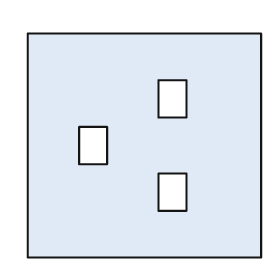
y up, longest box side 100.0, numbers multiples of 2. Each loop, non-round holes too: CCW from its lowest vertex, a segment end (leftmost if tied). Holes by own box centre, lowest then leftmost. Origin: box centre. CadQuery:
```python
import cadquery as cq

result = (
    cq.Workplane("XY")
    .moveTo(-50.0, -48.0)
    .lineTo(50.0, -48.0)
    .lineTo(50.0, 48.0)
    .lineTo(-50.0, 48.0)
    .close()
    .moveTo(6.0, -28.0)
    .lineTo(18.0, -28.0)
    .lineTo(18.0, -12.0)
    .lineTo(6.0, -12.0)
    .close()
    .moveTo(-28.0, -8.0)
    .lineTo(-16.0, -8.0)
    .lineTo(-16.0, 8.0)
    .lineTo(-28.0, 8.0)
    .close()
    .moveTo(6.0, 12.0)
    .lineTo(18.0, 12.0)
    .lineTo(18.0, 28.0)
    .lineTo(6.0, 28.0)
    .close()
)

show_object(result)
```